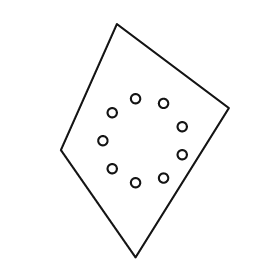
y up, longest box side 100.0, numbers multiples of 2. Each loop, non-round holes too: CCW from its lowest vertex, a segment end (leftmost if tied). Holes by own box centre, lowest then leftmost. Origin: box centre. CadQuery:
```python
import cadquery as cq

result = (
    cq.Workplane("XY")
    .moveTo(-4.0, -50.0)
    .lineTo(36.0, 14.0)
    .lineTo(-12.0, 50.0)
    .lineTo(-36.0, -4.0)
    .close()
    .moveTo(-4.0, -18.0)
    .circle(2.0)
    .moveTo(8.0, -16.0)
    .circle(2.0)
    .moveTo(-14.0, -12.0)
    .circle(2.0)
    .moveTo(16.0, -6.0)
    .circle(2.0)
    .moveTo(-18.0, 0.0)
    .circle(2.0)
    .moveTo(16.0, 6.0)
    .circle(2.0)
    .moveTo(-14.0, 12.0)
    .circle(2.0)
    .moveTo(8.0, 16.0)
    .circle(2.0)
    .moveTo(-4.0, 18.0)
    .circle(2.0)
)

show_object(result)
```